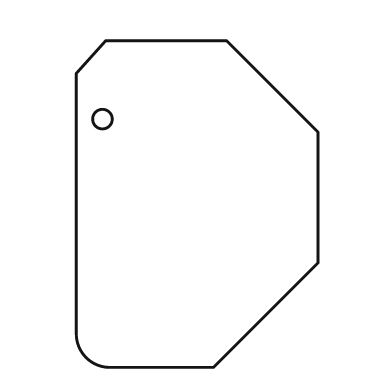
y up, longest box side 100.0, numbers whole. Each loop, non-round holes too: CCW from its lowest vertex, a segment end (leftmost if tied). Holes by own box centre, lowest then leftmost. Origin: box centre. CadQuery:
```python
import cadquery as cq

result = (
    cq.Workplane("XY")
    .moveTo(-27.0, -50.0)
    .lineTo(5.0, -50.0)
    .lineTo(37.0, -18.0)
    .lineTo(37.0, 22.0)
    .lineTo(9.0, 50.0)
    .lineTo(-28.0, 50.0)
    .lineTo(-37.0, 40.0)
    .lineTo(-37.0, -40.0)
    .threePointArc((-34.0, -47.0), (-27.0, -50.0))
    .close()
    .moveTo(-29.0, 26.0)
    .circle(3.0)
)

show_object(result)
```